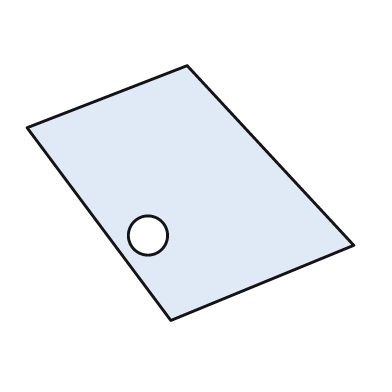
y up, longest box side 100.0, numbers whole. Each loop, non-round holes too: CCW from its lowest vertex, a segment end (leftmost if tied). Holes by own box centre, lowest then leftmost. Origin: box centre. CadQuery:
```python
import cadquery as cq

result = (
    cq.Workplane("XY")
    .moveTo(-6.0, -39.0)
    .lineTo(50.0, -16.0)
    .lineTo(-1.0, 39.0)
    .lineTo(-50.0, 20.0)
    .close()
    .moveTo(-13.0, -13.0)
    .circle(6.0)
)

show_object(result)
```